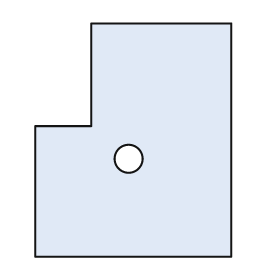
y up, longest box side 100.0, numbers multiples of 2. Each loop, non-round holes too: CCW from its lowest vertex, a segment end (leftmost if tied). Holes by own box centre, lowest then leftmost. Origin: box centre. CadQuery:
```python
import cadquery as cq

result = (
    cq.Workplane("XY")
    .moveTo(-42.0, -50.0)
    .lineTo(42.0, -50.0)
    .lineTo(42.0, 50.0)
    .lineTo(-18.0, 50.0)
    .lineTo(-18.0, 6.0)
    .lineTo(-42.0, 6.0)
    .close()
    .moveTo(-2.0, -8.0)
    .circle(6.0)
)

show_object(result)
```